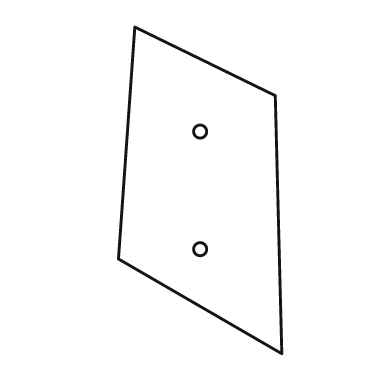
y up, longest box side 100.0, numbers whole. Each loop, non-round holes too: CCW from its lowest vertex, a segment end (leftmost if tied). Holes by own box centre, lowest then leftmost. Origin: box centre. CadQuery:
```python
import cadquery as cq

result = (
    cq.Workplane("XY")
    .moveTo(25.0, -50.0)
    .lineTo(23.0, 29.0)
    .lineTo(-20.0, 50.0)
    .lineTo(-25.0, -21.0)
    .close()
    .moveTo(0.0, -18.0)
    .circle(2.0)
    .moveTo(0.0, 18.0)
    .circle(2.0)
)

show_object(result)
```